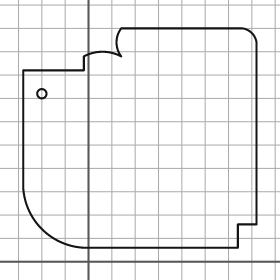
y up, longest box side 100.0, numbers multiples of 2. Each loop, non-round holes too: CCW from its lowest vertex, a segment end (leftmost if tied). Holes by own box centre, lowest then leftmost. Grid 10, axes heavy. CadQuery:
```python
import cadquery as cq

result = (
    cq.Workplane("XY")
    .moveTo(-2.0, 6.0)
    .lineTo(64.0, 6.0)
    .lineTo(64.0, 16.0)
    .lineTo(72.0, 16.0)
    .lineTo(72.0, 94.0)
    .threePointArc((70.0, 98.0), (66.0, 100.0))
    .lineTo(14.0, 100.0)
    .threePointArc((12.0, 94.0), (14.0, 88.0))
    .threePointArc((6.0, 90.0), (-2.0, 88.0))
    .lineTo(-2.0, 82.0)
    .lineTo(-28.0, 82.0)
    .lineTo(-28.0, 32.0)
    .threePointArc((-20.0, 14.0), (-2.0, 6.0))
    .close()
    .moveTo(-20.0, 72.0)
    .circle(2.0)
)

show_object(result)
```